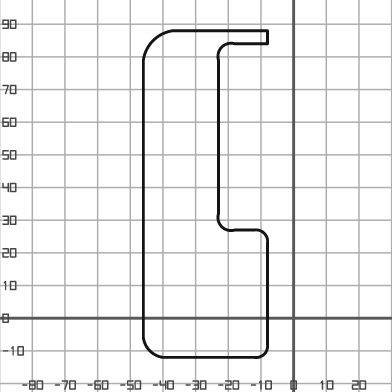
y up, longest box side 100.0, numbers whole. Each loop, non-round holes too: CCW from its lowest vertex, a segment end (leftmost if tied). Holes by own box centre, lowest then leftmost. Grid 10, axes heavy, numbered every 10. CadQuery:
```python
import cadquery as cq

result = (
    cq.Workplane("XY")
    .moveTo(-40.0, -12.0)
    .lineTo(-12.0, -12.0)
    .threePointArc((-9.0, -11.0), (-8.0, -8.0))
    .lineTo(-8.0, 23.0)
    .threePointArc((-9.0, 26.0), (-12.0, 27.0))
    .lineTo(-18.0, 27.0)
    .threePointArc((-22.0, 28.0), (-23.0, 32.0))
    .lineTo(-23.0, 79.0)
    .threePointArc((-22.0, 83.0), (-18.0, 84.0))
    .lineTo(-8.0, 84.0)
    .lineTo(-8.0, 88.0)
    .lineTo(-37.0, 88.0)
    .threePointArc((-43.0, 85.0), (-46.0, 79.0))
    .lineTo(-46.0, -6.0)
    .threePointArc((-44.0, -10.0), (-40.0, -12.0))
    .close()
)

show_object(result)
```